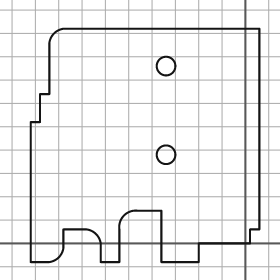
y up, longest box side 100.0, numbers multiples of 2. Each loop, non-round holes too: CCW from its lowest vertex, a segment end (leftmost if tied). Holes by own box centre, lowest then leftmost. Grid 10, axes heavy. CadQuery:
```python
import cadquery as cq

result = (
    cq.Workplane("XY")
    .moveTo(-92.0, -8.0)
    .lineTo(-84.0, -8.0)
    .threePointArc((-80.0, -6.0), (-78.0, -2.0))
    .lineTo(-78.0, 6.0)
    .lineTo(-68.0, 6.0)
    .threePointArc((-64.0, 4.0), (-62.0, 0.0))
    .lineTo(-62.0, -8.0)
    .lineTo(-54.0, -8.0)
    .lineTo(-54.0, 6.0)
    .threePointArc((-52.0, 12.0), (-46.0, 14.0))
    .lineTo(-36.0, 14.0)
    .lineTo(-36.0, -8.0)
    .lineTo(-20.0, -8.0)
    .lineTo(-20.0, 0.0)
    .lineTo(2.0, 0.0)
    .lineTo(2.0, 6.0)
    .lineTo(6.0, 6.0)
    .lineTo(6.0, 92.0)
    .lineTo(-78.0, 92.0)
    .threePointArc((-82.0, 90.0), (-84.0, 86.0))
    .lineTo(-84.0, 64.0)
    .lineTo(-88.0, 64.0)
    .lineTo(-88.0, 52.0)
    .lineTo(-92.0, 52.0)
    .close()
    .moveTo(-34.0, 38.0)
    .circle(4.0)
    .moveTo(-34.0, 76.0)
    .circle(4.0)
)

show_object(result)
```